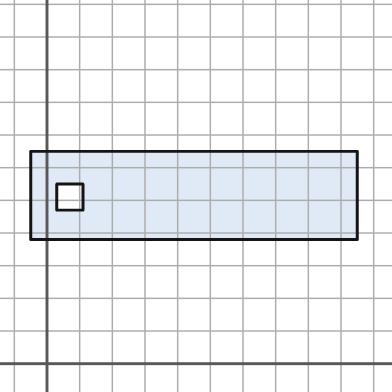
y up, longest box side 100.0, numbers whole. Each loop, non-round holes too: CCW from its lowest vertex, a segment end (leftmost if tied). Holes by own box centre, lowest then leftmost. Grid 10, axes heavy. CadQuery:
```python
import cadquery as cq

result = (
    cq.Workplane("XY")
    .moveTo(-5.0, 38.0)
    .lineTo(95.0, 38.0)
    .lineTo(95.0, 65.0)
    .lineTo(-5.0, 65.0)
    .close()
    .moveTo(3.0, 47.0)
    .lineTo(11.0, 47.0)
    .lineTo(11.0, 55.0)
    .lineTo(3.0, 55.0)
    .close()
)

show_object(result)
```